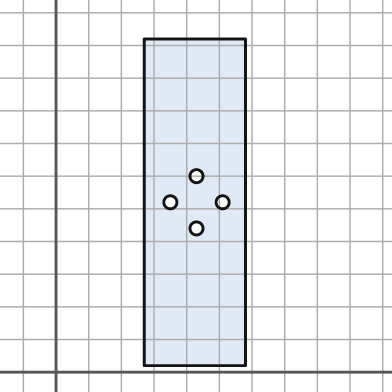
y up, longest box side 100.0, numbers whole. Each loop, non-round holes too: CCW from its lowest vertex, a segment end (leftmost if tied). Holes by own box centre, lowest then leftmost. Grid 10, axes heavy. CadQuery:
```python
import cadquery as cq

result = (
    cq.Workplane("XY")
    .moveTo(27.0, 2.0)
    .lineTo(58.0, 2.0)
    .lineTo(58.0, 102.0)
    .lineTo(27.0, 102.0)
    .close()
    .moveTo(43.0, 44.0)
    .circle(2.0)
    .moveTo(35.0, 52.0)
    .circle(2.0)
    .moveTo(51.0, 52.0)
    .circle(2.0)
    .moveTo(43.0, 60.0)
    .circle(2.0)
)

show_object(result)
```